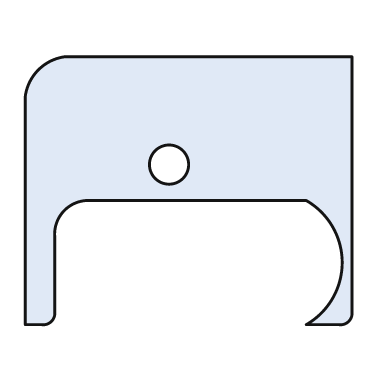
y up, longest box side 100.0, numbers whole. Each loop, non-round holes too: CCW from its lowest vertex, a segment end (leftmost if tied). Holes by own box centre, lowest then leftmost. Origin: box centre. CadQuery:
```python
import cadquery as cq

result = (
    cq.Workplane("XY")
    .moveTo(-50.0, -41.0)
    .lineTo(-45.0, -41.0)
    .threePointArc((-42.0, -40.0), (-41.0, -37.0))
    .lineTo(-41.0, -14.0)
    .threePointArc((-38.0, -6.0), (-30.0, -3.0))
    .lineTo(36.0, -3.0)
    .threePointArc((47.0, -22.0), (36.0, -41.0))
    .lineTo(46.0, -41.0)
    .threePointArc((49.0, -40.0), (50.0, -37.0))
    .lineTo(50.0, 41.0)
    .lineTo(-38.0, 41.0)
    .threePointArc((-46.0, 37.0), (-50.0, 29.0))
    .close()
    .moveTo(-6.0, 8.0)
    .circle(6.0)
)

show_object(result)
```